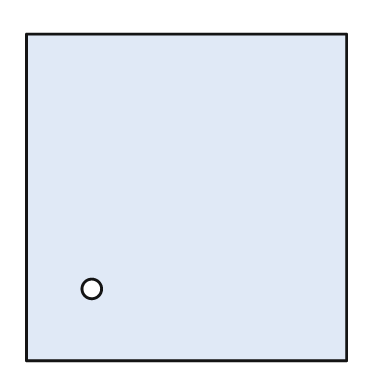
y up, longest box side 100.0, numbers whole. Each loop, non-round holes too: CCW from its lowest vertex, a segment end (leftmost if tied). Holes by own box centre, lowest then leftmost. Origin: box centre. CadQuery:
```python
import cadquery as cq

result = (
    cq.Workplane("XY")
    .moveTo(-49.0, -50.0)
    .lineTo(49.0, -50.0)
    .lineTo(49.0, 50.0)
    .lineTo(-49.0, 50.0)
    .close()
    .moveTo(-29.0, -28.0)
    .circle(3.0)
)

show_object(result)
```